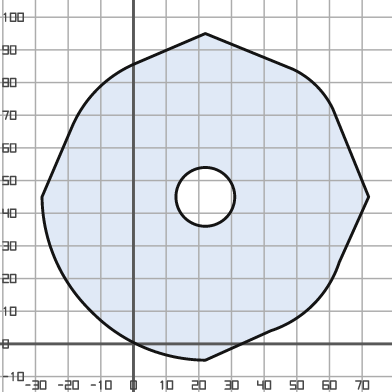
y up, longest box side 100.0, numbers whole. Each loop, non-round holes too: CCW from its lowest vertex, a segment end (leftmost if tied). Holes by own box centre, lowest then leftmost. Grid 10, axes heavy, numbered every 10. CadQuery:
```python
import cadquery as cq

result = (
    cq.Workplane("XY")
    .moveTo(22.0, -5.0)
    .lineTo(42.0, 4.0)
    .threePointArc((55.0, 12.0), (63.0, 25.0))
    .lineTo(72.0, 45.0)
    .lineTo(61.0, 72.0)
    .threePointArc((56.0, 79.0), (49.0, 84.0))
    .lineTo(22.0, 95.0)
    .lineTo(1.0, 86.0)
    .threePointArc((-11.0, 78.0), (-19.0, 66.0))
    .lineTo(-28.0, 45.0)
    .threePointArc((-24.0, 26.0), (-13.0, 10.0))
    .threePointArc((3.0, -1.0), (22.0, -5.0))
    .close()
    .moveTo(22.0, 45.0)
    .circle(9.0)
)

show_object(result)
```